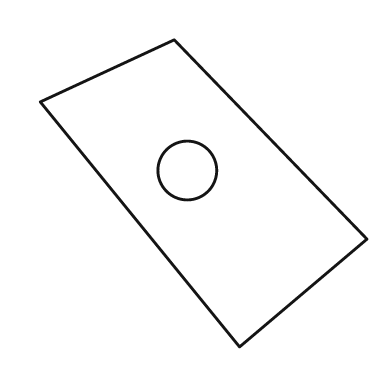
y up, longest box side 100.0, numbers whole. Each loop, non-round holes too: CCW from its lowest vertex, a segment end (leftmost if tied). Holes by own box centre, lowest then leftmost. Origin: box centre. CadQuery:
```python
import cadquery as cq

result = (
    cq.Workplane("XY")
    .moveTo(11.0, -47.0)
    .lineTo(50.0, -14.0)
    .lineTo(-9.0, 47.0)
    .lineTo(-50.0, 28.0)
    .close()
    .moveTo(-5.0, 7.0)
    .circle(9.0)
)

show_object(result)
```